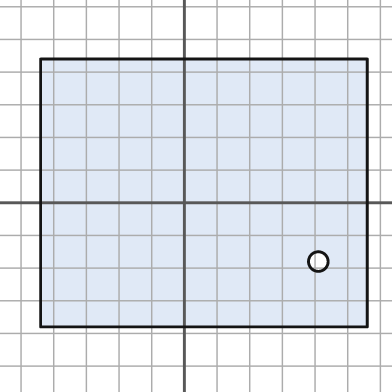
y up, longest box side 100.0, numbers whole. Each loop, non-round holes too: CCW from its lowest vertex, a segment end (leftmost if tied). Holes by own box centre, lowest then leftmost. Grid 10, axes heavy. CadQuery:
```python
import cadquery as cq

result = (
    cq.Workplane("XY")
    .moveTo(-44.0, -38.0)
    .lineTo(56.0, -38.0)
    .lineTo(56.0, 44.0)
    .lineTo(-44.0, 44.0)
    .close()
    .moveTo(41.0, -18.0)
    .circle(3.0)
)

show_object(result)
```